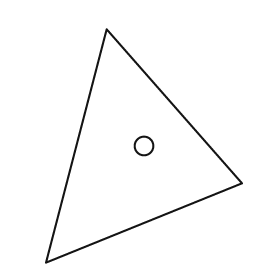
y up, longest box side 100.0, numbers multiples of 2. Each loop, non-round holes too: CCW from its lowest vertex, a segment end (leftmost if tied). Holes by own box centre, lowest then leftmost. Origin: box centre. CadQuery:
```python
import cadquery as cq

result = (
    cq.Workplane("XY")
    .moveTo(-42.0, -50.0)
    .lineTo(42.0, -16.0)
    .lineTo(-16.0, 50.0)
    .close()
    .moveTo(0.0, 0.0)
    .circle(4.0)
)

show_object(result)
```